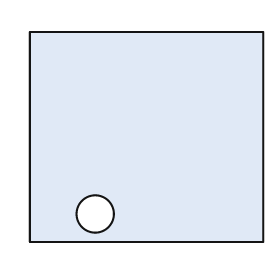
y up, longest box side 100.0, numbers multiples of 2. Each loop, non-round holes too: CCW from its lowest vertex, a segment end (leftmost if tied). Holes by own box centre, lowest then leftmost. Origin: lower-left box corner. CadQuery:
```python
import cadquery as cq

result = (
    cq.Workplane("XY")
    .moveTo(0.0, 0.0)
    .lineTo(100.0, 0.0)
    .lineTo(100.0, 90.0)
    .lineTo(0.0, 90.0)
    .close()
    .moveTo(28.0, 12.0)
    .circle(8.0)
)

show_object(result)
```